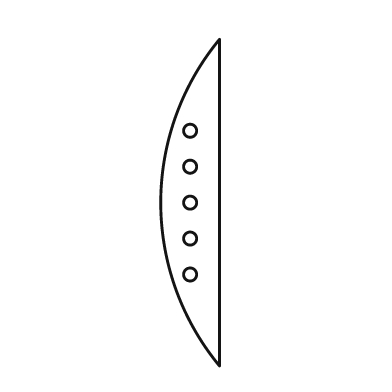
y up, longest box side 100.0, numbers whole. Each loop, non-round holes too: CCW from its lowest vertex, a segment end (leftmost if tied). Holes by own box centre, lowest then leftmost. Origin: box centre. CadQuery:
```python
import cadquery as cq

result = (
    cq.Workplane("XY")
    .moveTo(9.0, -50.0)
    .lineTo(9.0, 50.0)
    .threePointArc((-9.0, 0.0), (9.0, -50.0))
    .close()
    .moveTo(0.0, -22.0)
    .circle(2.0)
    .moveTo(0.0, -11.0)
    .circle(2.0)
    .moveTo(0.0, 0.0)
    .circle(2.0)
    .moveTo(0.0, 11.0)
    .circle(2.0)
    .moveTo(0.0, 22.0)
    .circle(2.0)
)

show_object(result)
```